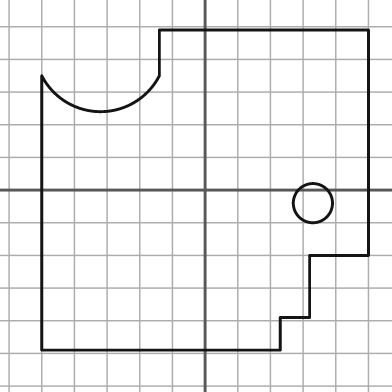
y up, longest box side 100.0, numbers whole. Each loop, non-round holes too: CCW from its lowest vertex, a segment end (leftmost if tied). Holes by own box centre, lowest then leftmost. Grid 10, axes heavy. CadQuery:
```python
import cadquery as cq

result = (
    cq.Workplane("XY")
    .moveTo(-50.0, -49.0)
    .lineTo(23.0, -49.0)
    .lineTo(23.0, -39.0)
    .lineTo(32.0, -39.0)
    .lineTo(32.0, -20.0)
    .lineTo(50.0, -20.0)
    .lineTo(50.0, 49.0)
    .lineTo(-14.0, 49.0)
    .lineTo(-14.0, 35.0)
    .threePointArc((-32.0, 24.0), (-50.0, 35.0))
    .close()
    .moveTo(33.0, -4.0)
    .circle(6.0)
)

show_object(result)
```